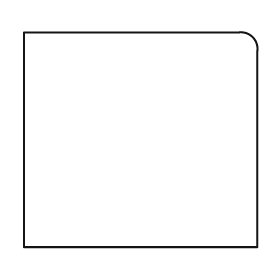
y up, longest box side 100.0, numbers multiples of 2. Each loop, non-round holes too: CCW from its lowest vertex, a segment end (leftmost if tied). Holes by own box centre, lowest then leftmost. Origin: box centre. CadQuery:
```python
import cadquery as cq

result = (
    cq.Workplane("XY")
    .moveTo(-50.0, -46.0)
    .lineTo(50.0, -46.0)
    .lineTo(50.0, 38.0)
    .threePointArc((48.0, 44.0), (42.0, 46.0))
    .lineTo(-50.0, 46.0)
    .close()
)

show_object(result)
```